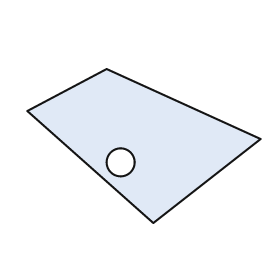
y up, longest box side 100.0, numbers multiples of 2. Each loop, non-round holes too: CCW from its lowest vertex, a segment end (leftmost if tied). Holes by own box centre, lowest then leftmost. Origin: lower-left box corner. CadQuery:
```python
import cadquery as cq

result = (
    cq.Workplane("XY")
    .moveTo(54.0, 0.0)
    .lineTo(100.0, 36.0)
    .lineTo(34.0, 66.0)
    .lineTo(0.0, 48.0)
    .close()
    .moveTo(40.0, 26.0)
    .circle(6.0)
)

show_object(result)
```